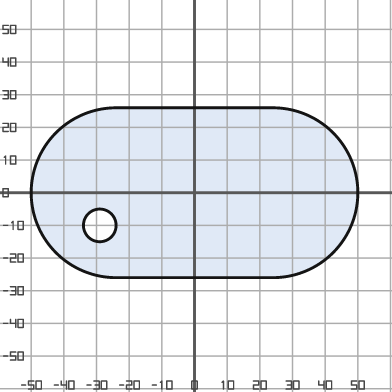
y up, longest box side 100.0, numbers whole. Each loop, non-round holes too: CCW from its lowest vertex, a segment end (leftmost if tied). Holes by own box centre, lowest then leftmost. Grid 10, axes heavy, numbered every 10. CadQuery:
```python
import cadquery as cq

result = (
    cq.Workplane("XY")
    .moveTo(-24.0, -26.0)
    .lineTo(24.0, -26.0)
    .threePointArc((50.0, 0.0), (24.0, 26.0))
    .lineTo(-24.0, 26.0)
    .threePointArc((-50.0, 0.0), (-24.0, -26.0))
    .close()
    .moveTo(-29.0, -10.0)
    .circle(5.0)
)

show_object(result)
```